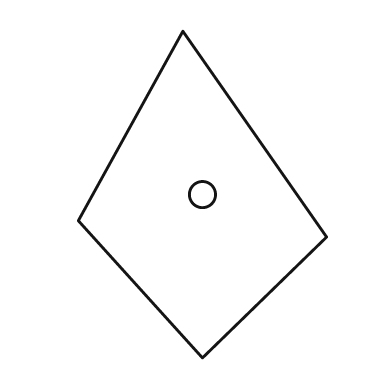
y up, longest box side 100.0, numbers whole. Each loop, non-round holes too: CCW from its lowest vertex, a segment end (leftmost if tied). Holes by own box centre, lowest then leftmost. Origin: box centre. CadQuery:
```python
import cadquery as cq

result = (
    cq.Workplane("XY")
    .moveTo(0.0, -50.0)
    .lineTo(38.0, -13.0)
    .lineTo(-6.0, 50.0)
    .lineTo(-38.0, -8.0)
    .close()
    .moveTo(0.0, 0.0)
    .circle(4.0)
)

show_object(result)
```